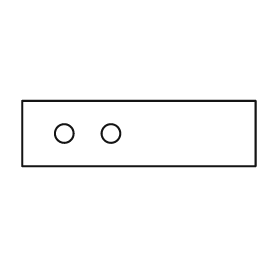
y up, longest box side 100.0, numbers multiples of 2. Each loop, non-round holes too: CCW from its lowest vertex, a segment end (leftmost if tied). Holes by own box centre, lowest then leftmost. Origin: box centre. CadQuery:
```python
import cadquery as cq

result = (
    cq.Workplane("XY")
    .moveTo(-50.0, -14.0)
    .lineTo(50.0, -14.0)
    .lineTo(50.0, 14.0)
    .lineTo(-50.0, 14.0)
    .close()
    .moveTo(-32.0, 0.0)
    .circle(4.0)
    .moveTo(-12.0, 0.0)
    .circle(4.0)
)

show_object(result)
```